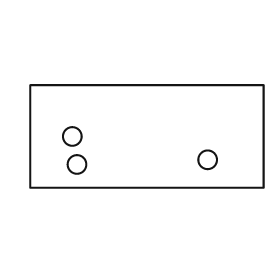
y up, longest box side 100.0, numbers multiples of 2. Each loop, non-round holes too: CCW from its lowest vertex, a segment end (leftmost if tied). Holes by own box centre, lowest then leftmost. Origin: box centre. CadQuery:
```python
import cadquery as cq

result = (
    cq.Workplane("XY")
    .moveTo(-50.0, -22.0)
    .lineTo(50.0, -22.0)
    .lineTo(50.0, 22.0)
    .lineTo(-50.0, 22.0)
    .close()
    .moveTo(-30.0, -12.0)
    .circle(4.0)
    .moveTo(26.0, -10.0)
    .circle(4.0)
    .moveTo(-32.0, 0.0)
    .circle(4.0)
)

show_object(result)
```